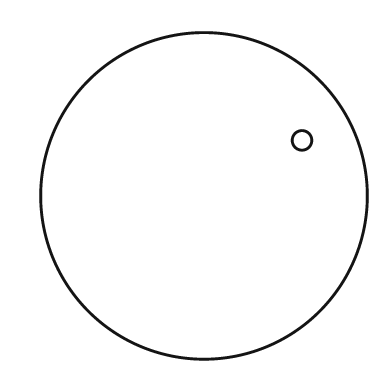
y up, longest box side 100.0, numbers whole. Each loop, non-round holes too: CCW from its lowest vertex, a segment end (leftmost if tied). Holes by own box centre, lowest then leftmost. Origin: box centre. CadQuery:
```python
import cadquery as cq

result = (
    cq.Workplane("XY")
    .moveTo(0.0, 0.0)
    .circle(50.0)
    .moveTo(30.0, 17.0)
    .circle(3.0)
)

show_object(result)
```